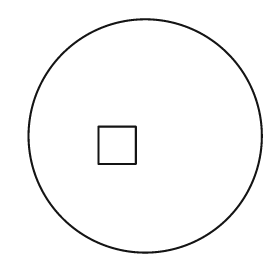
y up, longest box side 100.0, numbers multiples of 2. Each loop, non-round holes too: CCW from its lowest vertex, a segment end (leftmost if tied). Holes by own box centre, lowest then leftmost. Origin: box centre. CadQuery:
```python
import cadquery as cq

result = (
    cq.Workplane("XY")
    .moveTo(0.0, 0.0)
    .circle(50.0)
    .moveTo(-20.0, -12.0)
    .lineTo(-4.0, -12.0)
    .lineTo(-4.0, 4.0)
    .lineTo(-20.0, 4.0)
    .close()
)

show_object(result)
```